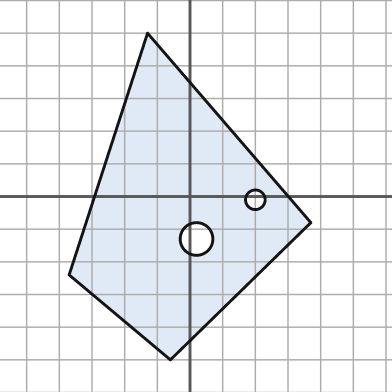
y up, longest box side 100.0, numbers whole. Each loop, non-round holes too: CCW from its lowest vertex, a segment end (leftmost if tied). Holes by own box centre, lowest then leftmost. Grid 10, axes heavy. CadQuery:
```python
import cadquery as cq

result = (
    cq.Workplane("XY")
    .moveTo(-6.0, -50.0)
    .lineTo(37.0, -8.0)
    .lineTo(-13.0, 50.0)
    .lineTo(-37.0, -24.0)
    .close()
    .moveTo(2.0, -13.0)
    .circle(5.0)
    .moveTo(20.0, -1.0)
    .circle(3.0)
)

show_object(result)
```